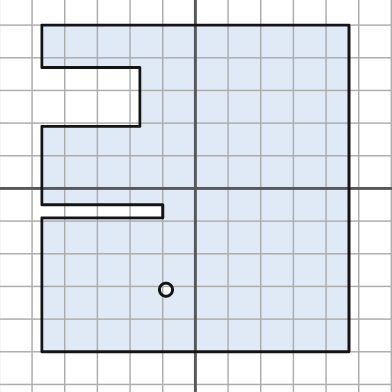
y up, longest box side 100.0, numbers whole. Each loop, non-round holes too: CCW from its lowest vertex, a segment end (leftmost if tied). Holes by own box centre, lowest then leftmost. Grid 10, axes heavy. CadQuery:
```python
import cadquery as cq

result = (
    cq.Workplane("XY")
    .moveTo(-47.0, -50.0)
    .lineTo(47.0, -50.0)
    .lineTo(47.0, 50.0)
    .lineTo(-47.0, 50.0)
    .lineTo(-47.0, 37.0)
    .lineTo(-17.0, 37.0)
    .lineTo(-17.0, 19.0)
    .lineTo(-47.0, 19.0)
    .lineTo(-47.0, -5.0)
    .lineTo(-10.0, -5.0)
    .lineTo(-10.0, -9.0)
    .lineTo(-47.0, -9.0)
    .close()
    .moveTo(-9.0, -31.0)
    .circle(2.0)
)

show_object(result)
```